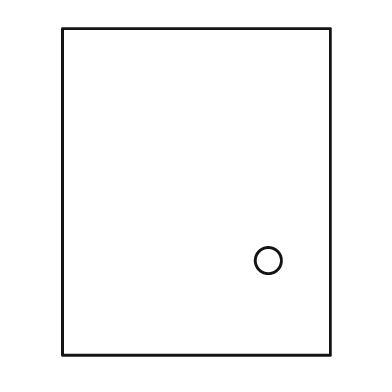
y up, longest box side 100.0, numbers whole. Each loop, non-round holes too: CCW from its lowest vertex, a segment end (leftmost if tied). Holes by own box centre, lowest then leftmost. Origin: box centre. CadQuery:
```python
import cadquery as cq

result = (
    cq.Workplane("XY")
    .moveTo(-41.0, -50.0)
    .lineTo(41.0, -50.0)
    .lineTo(41.0, 50.0)
    .lineTo(-41.0, 50.0)
    .close()
    .moveTo(22.0, -21.0)
    .circle(4.0)
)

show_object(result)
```